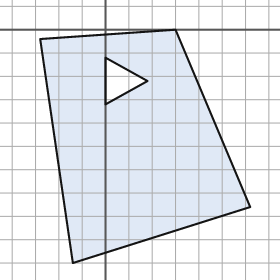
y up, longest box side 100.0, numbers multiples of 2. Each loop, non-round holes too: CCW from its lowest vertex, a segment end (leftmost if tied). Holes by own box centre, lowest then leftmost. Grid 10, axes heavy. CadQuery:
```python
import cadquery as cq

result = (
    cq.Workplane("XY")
    .moveTo(-14.0, -100.0)
    .lineTo(62.0, -76.0)
    .lineTo(30.0, 0.0)
    .lineTo(-28.0, -4.0)
    .close()
    .moveTo(0.0, -32.0)
    .lineTo(18.0, -22.0)
    .lineTo(0.0, -12.0)
    .close()
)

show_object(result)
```